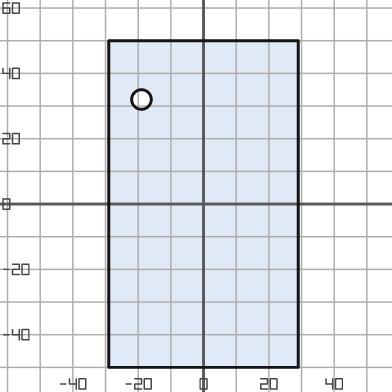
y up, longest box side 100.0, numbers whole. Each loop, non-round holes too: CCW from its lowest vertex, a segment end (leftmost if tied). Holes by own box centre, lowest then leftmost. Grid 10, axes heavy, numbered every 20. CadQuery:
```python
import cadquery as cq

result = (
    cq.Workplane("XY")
    .moveTo(-29.0, -50.0)
    .lineTo(29.0, -50.0)
    .lineTo(29.0, 50.0)
    .lineTo(-29.0, 50.0)
    .close()
    .moveTo(-19.0, 32.0)
    .circle(3.0)
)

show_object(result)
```